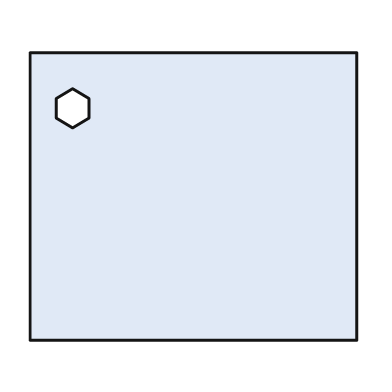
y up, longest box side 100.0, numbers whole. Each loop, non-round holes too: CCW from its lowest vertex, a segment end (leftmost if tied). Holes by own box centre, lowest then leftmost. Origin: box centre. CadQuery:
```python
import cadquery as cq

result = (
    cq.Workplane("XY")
    .moveTo(-50.0, -44.0)
    .lineTo(50.0, -44.0)
    .lineTo(50.0, 44.0)
    .lineTo(-50.0, 44.0)
    .close()
    .moveTo(-37.0, 21.0)
    .lineTo(-32.0, 24.0)
    .lineTo(-32.0, 30.0)
    .lineTo(-37.0, 33.0)
    .lineTo(-42.0, 30.0)
    .lineTo(-42.0, 24.0)
    .close()
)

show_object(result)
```